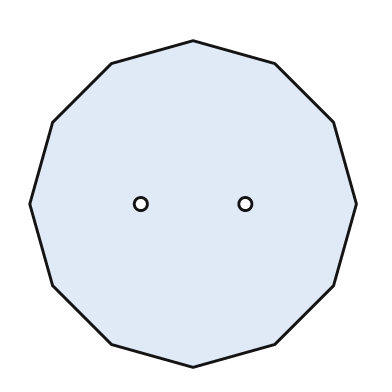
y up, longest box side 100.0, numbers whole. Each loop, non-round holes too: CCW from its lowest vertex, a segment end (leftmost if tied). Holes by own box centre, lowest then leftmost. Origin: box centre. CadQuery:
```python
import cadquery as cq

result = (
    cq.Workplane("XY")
    .moveTo(0.0, -50.0)
    .lineTo(25.0, -43.0)
    .lineTo(43.0, -25.0)
    .lineTo(50.0, 0.0)
    .lineTo(43.0, 25.0)
    .lineTo(25.0, 43.0)
    .lineTo(0.0, 50.0)
    .lineTo(-25.0, 43.0)
    .lineTo(-43.0, 25.0)
    .lineTo(-50.0, 0.0)
    .lineTo(-43.0, -25.0)
    .lineTo(-25.0, -43.0)
    .close()
    .moveTo(-16.0, 0.0)
    .circle(2.0)
    .moveTo(16.0, 0.0)
    .circle(2.0)
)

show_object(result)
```